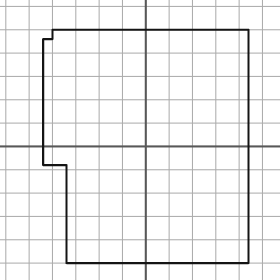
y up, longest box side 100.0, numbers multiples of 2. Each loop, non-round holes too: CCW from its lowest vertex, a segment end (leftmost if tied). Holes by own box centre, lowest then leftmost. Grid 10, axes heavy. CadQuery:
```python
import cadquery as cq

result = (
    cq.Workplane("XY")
    .moveTo(-34.0, -50.0)
    .lineTo(44.0, -50.0)
    .lineTo(44.0, 50.0)
    .lineTo(-40.0, 50.0)
    .lineTo(-40.0, 46.0)
    .lineTo(-44.0, 46.0)
    .lineTo(-44.0, -8.0)
    .lineTo(-34.0, -8.0)
    .close()
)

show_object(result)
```